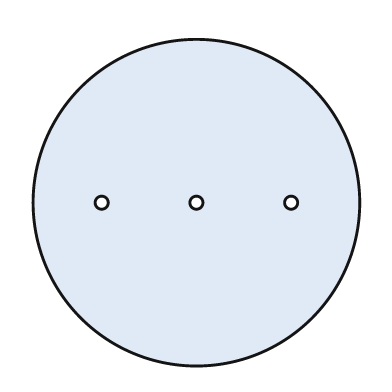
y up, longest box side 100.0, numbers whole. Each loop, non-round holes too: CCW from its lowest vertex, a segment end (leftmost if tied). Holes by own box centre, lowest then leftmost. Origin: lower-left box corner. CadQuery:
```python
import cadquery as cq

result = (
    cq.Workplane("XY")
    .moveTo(50.0, 50.0)
    .circle(50.0)
    .moveTo(21.0, 50.0)
    .circle(2.0)
    .moveTo(50.0, 50.0)
    .circle(2.0)
    .moveTo(79.0, 50.0)
    .circle(2.0)
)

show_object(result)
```